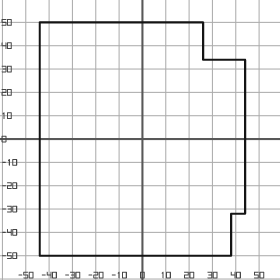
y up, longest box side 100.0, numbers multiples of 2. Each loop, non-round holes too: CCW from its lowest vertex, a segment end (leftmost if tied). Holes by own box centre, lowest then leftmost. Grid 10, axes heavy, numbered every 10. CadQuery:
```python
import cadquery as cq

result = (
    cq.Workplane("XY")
    .moveTo(-44.0, -50.0)
    .lineTo(38.0, -50.0)
    .lineTo(38.0, -32.0)
    .lineTo(44.0, -32.0)
    .lineTo(44.0, 34.0)
    .lineTo(26.0, 34.0)
    .lineTo(26.0, 50.0)
    .lineTo(-44.0, 50.0)
    .close()
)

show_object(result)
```